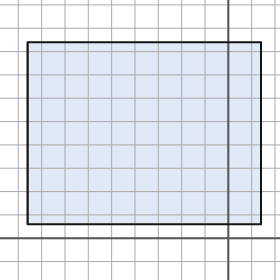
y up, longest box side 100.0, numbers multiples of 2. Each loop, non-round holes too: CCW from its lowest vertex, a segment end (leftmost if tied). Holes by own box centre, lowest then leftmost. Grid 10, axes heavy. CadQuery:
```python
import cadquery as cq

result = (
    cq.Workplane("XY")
    .moveTo(-86.0, 6.0)
    .lineTo(14.0, 6.0)
    .lineTo(14.0, 84.0)
    .lineTo(-86.0, 84.0)
    .close()
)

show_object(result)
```